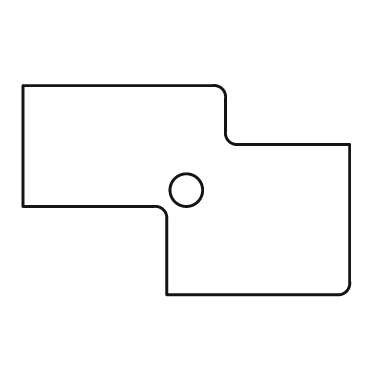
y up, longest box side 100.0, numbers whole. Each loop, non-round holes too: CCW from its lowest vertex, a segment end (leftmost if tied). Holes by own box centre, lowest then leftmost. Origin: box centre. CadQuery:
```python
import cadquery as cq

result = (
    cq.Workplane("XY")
    .moveTo(-6.0, -32.0)
    .lineTo(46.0, -32.0)
    .threePointArc((49.0, -31.0), (50.0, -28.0))
    .lineTo(50.0, 14.0)
    .lineTo(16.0, 14.0)
    .threePointArc((13.0, 15.0), (12.0, 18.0))
    .lineTo(12.0, 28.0)
    .threePointArc((11.0, 31.0), (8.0, 32.0))
    .lineTo(-50.0, 32.0)
    .lineTo(-50.0, -5.0)
    .lineTo(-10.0, -5.0)
    .threePointArc((-7.0, -6.0), (-6.0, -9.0))
    .close()
    .moveTo(0.0, 0.0)
    .circle(5.0)
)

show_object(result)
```